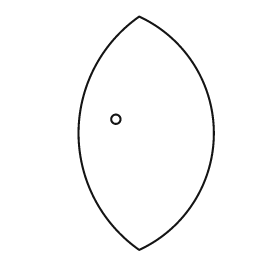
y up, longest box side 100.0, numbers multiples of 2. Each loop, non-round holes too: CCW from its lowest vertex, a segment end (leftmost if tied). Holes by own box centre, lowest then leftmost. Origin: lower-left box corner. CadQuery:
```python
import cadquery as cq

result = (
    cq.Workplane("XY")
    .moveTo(26.0, 0.0)
    .threePointArc((58.0, 50.0), (26.0, 100.0))
    .threePointArc((0.0, 50.0), (26.0, 0.0))
    .close()
    .moveTo(16.0, 56.0)
    .circle(2.0)
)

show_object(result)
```